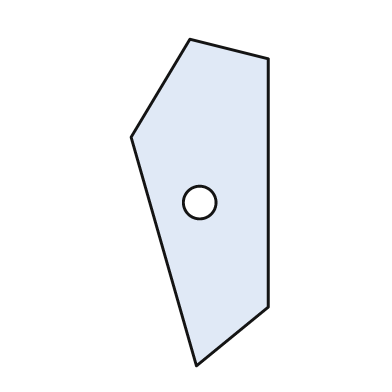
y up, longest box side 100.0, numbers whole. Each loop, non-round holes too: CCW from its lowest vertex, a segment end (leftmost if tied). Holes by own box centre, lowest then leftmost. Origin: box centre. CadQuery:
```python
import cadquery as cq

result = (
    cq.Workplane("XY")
    .moveTo(-1.0, -50.0)
    .lineTo(21.0, -32.0)
    .lineTo(21.0, 44.0)
    .lineTo(-3.0, 50.0)
    .lineTo(-21.0, 20.0)
    .close()
    .moveTo(0.0, 0.0)
    .circle(5.0)
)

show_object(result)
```